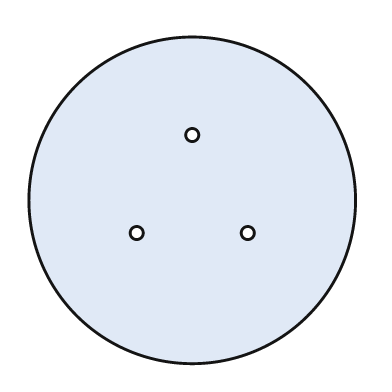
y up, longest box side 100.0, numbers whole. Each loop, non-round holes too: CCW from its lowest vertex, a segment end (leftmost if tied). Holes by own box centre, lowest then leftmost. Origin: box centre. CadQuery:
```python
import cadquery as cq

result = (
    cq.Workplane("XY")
    .moveTo(0.0, 0.0)
    .circle(50.0)
    .moveTo(-17.0, -10.0)
    .circle(2.0)
    .moveTo(17.0, -10.0)
    .circle(2.0)
    .moveTo(0.0, 20.0)
    .circle(2.0)
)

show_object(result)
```